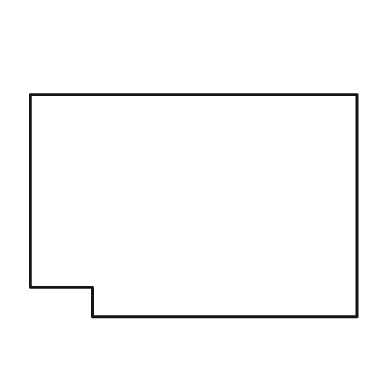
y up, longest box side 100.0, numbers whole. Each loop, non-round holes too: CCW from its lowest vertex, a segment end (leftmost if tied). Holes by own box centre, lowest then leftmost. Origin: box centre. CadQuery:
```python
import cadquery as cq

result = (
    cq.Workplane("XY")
    .moveTo(-31.0, -34.0)
    .lineTo(50.0, -34.0)
    .lineTo(50.0, 34.0)
    .lineTo(-50.0, 34.0)
    .lineTo(-50.0, -25.0)
    .lineTo(-31.0, -25.0)
    .close()
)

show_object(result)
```